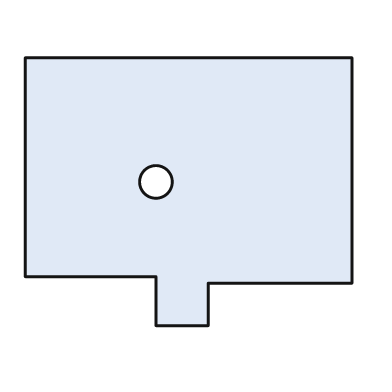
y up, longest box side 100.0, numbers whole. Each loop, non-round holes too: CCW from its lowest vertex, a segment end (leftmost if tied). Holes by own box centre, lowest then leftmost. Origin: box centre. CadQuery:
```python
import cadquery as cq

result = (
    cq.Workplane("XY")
    .moveTo(-10.0, -41.0)
    .lineTo(6.0, -41.0)
    .lineTo(6.0, -28.0)
    .lineTo(50.0, -28.0)
    .lineTo(50.0, 41.0)
    .lineTo(-50.0, 41.0)
    .lineTo(-50.0, -26.0)
    .lineTo(-10.0, -26.0)
    .close()
    .moveTo(-10.0, 3.0)
    .circle(5.0)
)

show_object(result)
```